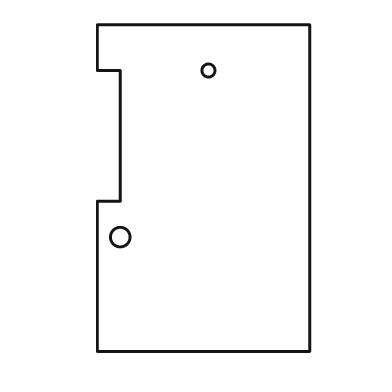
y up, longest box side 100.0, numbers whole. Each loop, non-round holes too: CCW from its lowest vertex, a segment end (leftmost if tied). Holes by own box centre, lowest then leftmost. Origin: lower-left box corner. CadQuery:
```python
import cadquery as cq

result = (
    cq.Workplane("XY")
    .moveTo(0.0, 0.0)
    .lineTo(65.0, 0.0)
    .lineTo(65.0, 100.0)
    .lineTo(0.0, 100.0)
    .lineTo(0.0, 86.0)
    .lineTo(7.0, 86.0)
    .lineTo(7.0, 46.0)
    .lineTo(0.0, 46.0)
    .close()
    .moveTo(7.0, 35.0)
    .circle(3.0)
    .moveTo(34.0, 86.0)
    .circle(2.0)
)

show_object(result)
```